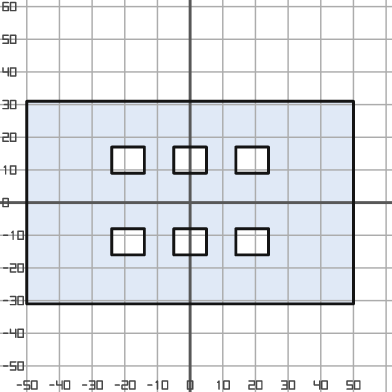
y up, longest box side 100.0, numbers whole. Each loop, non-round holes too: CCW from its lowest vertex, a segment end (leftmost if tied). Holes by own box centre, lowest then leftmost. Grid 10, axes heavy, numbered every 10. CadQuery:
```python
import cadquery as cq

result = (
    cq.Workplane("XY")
    .moveTo(-50.0, -31.0)
    .lineTo(50.0, -31.0)
    .lineTo(50.0, 31.0)
    .lineTo(-50.0, 31.0)
    .close()
    .moveTo(-24.0, -16.0)
    .lineTo(-14.0, -16.0)
    .lineTo(-14.0, -8.0)
    .lineTo(-24.0, -8.0)
    .close()
    .moveTo(-5.0, -16.0)
    .lineTo(5.0, -16.0)
    .lineTo(5.0, -8.0)
    .lineTo(-5.0, -8.0)
    .close()
    .moveTo(14.0, -16.0)
    .lineTo(24.0, -16.0)
    .lineTo(24.0, -8.0)
    .lineTo(14.0, -8.0)
    .close()
    .moveTo(-24.0, 9.0)
    .lineTo(-14.0, 9.0)
    .lineTo(-14.0, 17.0)
    .lineTo(-24.0, 17.0)
    .close()
    .moveTo(-5.0, 9.0)
    .lineTo(5.0, 9.0)
    .lineTo(5.0, 17.0)
    .lineTo(-5.0, 17.0)
    .close()
    .moveTo(14.0, 9.0)
    .lineTo(24.0, 9.0)
    .lineTo(24.0, 17.0)
    .lineTo(14.0, 17.0)
    .close()
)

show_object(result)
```